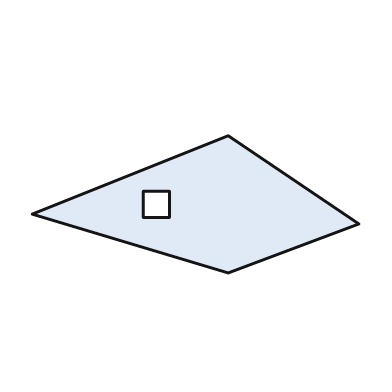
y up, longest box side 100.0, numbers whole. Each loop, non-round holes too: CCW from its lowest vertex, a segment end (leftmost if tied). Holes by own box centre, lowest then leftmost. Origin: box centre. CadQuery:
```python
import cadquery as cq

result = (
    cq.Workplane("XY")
    .moveTo(10.0, -21.0)
    .lineTo(50.0, -6.0)
    .lineTo(10.0, 21.0)
    .lineTo(-50.0, -3.0)
    .close()
    .moveTo(-16.0, -4.0)
    .lineTo(-8.0, -4.0)
    .lineTo(-8.0, 4.0)
    .lineTo(-16.0, 4.0)
    .close()
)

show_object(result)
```